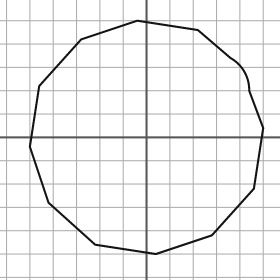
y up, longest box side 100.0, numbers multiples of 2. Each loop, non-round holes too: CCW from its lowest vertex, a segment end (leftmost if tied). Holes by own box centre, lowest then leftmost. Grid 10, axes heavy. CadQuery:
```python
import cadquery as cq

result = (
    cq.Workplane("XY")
    .moveTo(4.0, -50.0)
    .lineTo(28.0, -42.0)
    .lineTo(46.0, -22.0)
    .lineTo(50.0, 4.0)
    .lineTo(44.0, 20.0)
    .threePointArc((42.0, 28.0), (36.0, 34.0))
    .lineTo(22.0, 46.0)
    .lineTo(-4.0, 50.0)
    .lineTo(-28.0, 42.0)
    .lineTo(-46.0, 22.0)
    .lineTo(-50.0, -4.0)
    .lineTo(-42.0, -28.0)
    .lineTo(-22.0, -46.0)
    .close()
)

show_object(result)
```